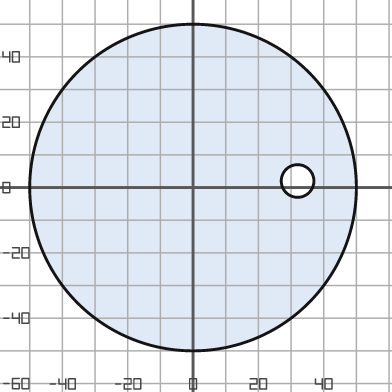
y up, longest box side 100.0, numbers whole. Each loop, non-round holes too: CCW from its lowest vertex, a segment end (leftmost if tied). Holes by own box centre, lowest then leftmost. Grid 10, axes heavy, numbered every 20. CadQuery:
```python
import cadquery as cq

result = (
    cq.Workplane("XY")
    .moveTo(0.0, 0.0)
    .circle(50.0)
    .moveTo(32.0, 2.0)
    .circle(5.0)
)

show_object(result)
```